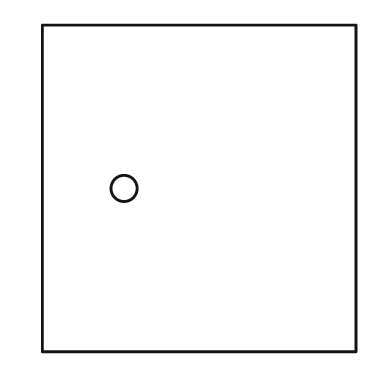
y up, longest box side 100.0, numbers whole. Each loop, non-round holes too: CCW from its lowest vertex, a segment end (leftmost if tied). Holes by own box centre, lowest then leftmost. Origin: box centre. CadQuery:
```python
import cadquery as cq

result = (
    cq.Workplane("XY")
    .moveTo(-48.0, -50.0)
    .lineTo(48.0, -50.0)
    .lineTo(48.0, 50.0)
    .lineTo(-48.0, 50.0)
    .close()
    .moveTo(-23.0, 0.0)
    .circle(4.0)
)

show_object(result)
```